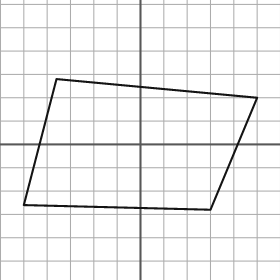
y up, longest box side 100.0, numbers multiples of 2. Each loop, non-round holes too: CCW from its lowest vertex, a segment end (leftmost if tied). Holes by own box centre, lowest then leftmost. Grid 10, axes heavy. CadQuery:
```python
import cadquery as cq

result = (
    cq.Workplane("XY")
    .moveTo(30.0, -28.0)
    .lineTo(50.0, 20.0)
    .lineTo(-36.0, 28.0)
    .lineTo(-50.0, -26.0)
    .close()
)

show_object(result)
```